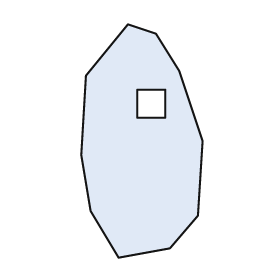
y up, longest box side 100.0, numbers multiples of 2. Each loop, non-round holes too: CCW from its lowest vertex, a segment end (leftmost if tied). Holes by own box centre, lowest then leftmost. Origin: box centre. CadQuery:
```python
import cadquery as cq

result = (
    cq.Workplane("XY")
    .moveTo(-10.0, -50.0)
    .lineTo(12.0, -46.0)
    .lineTo(24.0, -32.0)
    .lineTo(26.0, 0.0)
    .lineTo(16.0, 30.0)
    .lineTo(6.0, 46.0)
    .lineTo(-6.0, 50.0)
    .lineTo(-24.0, 28.0)
    .lineTo(-26.0, -6.0)
    .lineTo(-22.0, -30.0)
    .close()
    .moveTo(-2.0, 10.0)
    .lineTo(10.0, 10.0)
    .lineTo(10.0, 22.0)
    .lineTo(-2.0, 22.0)
    .close()
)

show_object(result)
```